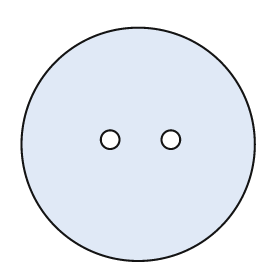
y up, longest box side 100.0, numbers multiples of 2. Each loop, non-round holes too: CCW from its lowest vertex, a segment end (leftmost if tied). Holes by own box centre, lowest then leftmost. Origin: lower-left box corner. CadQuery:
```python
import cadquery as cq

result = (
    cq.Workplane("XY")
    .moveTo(50.0, 50.0)
    .circle(50.0)
    .moveTo(38.0, 52.0)
    .circle(4.0)
    .moveTo(64.0, 52.0)
    .circle(4.0)
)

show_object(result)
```